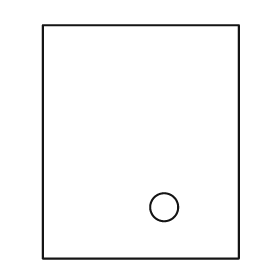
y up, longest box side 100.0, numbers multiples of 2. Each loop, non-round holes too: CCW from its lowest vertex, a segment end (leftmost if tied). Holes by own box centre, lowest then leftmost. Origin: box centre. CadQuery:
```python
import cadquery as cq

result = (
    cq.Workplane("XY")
    .moveTo(-42.0, -50.0)
    .lineTo(42.0, -50.0)
    .lineTo(42.0, 50.0)
    .lineTo(-42.0, 50.0)
    .close()
    .moveTo(10.0, -28.0)
    .circle(6.0)
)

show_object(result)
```